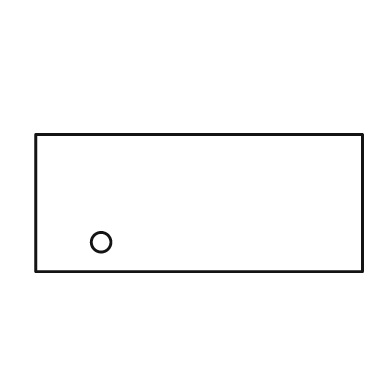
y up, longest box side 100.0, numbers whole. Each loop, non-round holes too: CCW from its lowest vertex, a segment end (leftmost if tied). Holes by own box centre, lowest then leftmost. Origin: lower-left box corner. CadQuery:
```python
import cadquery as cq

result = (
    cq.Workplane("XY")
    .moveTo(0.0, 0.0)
    .lineTo(100.0, 0.0)
    .lineTo(100.0, 42.0)
    .lineTo(0.0, 42.0)
    .close()
    .moveTo(20.0, 9.0)
    .circle(3.0)
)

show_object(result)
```